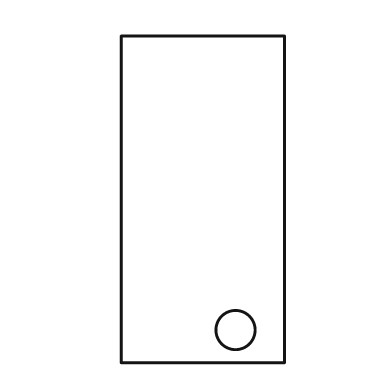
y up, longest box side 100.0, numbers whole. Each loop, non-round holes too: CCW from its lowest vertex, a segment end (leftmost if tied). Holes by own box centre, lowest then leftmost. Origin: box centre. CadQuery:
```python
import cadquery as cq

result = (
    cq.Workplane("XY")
    .moveTo(-25.0, -50.0)
    .lineTo(25.0, -50.0)
    .lineTo(25.0, 50.0)
    .lineTo(-25.0, 50.0)
    .close()
    .moveTo(10.0, -40.0)
    .circle(6.0)
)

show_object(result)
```